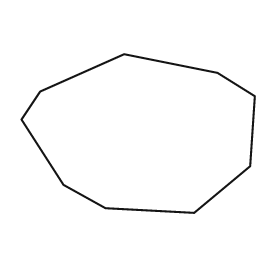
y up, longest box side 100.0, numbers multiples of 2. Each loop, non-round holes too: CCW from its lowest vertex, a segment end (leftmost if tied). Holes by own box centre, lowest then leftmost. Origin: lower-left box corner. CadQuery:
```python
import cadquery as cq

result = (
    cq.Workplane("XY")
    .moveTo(74.0, 0.0)
    .lineTo(98.0, 20.0)
    .lineTo(100.0, 50.0)
    .lineTo(84.0, 60.0)
    .lineTo(44.0, 68.0)
    .lineTo(8.0, 52.0)
    .lineTo(0.0, 40.0)
    .lineTo(18.0, 12.0)
    .lineTo(36.0, 2.0)
    .close()
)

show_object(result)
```